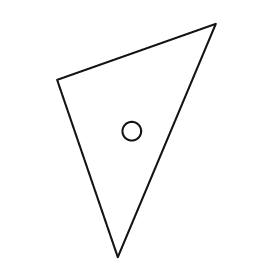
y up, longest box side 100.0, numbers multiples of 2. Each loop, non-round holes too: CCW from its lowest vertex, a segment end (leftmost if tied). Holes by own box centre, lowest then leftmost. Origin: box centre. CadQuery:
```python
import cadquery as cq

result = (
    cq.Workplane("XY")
    .moveTo(-8.0, -50.0)
    .lineTo(34.0, 50.0)
    .lineTo(-34.0, 26.0)
    .close()
    .moveTo(-2.0, 4.0)
    .circle(4.0)
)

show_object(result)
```